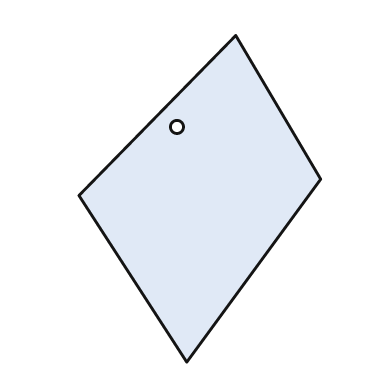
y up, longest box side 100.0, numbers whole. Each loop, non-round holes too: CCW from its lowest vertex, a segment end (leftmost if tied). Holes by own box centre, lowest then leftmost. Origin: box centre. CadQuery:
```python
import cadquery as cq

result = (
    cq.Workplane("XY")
    .moveTo(-4.0, -50.0)
    .lineTo(37.0, 6.0)
    .lineTo(11.0, 50.0)
    .lineTo(-37.0, 1.0)
    .close()
    .moveTo(-7.0, 22.0)
    .circle(2.0)
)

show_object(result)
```